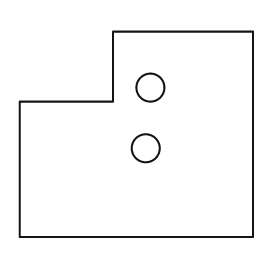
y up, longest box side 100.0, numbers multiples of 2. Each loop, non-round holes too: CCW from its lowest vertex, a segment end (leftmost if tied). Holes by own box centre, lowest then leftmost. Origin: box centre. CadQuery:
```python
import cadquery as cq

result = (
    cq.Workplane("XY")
    .moveTo(-50.0, -44.0)
    .lineTo(50.0, -44.0)
    .lineTo(50.0, 44.0)
    .lineTo(-10.0, 44.0)
    .lineTo(-10.0, 14.0)
    .lineTo(-50.0, 14.0)
    .close()
    .moveTo(4.0, -6.0)
    .circle(6.0)
    .moveTo(6.0, 20.0)
    .circle(6.0)
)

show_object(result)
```